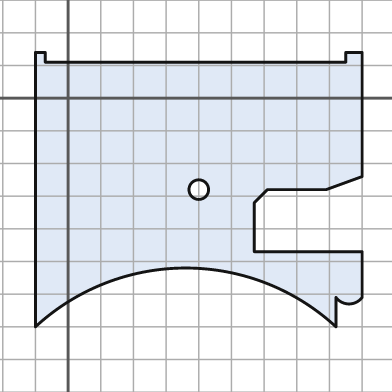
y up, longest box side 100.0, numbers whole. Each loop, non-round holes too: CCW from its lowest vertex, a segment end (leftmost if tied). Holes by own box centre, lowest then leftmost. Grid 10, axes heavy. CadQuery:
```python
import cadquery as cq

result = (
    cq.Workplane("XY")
    .moveTo(-10.0, -70.0)
    .threePointArc((36.0, -52.0), (82.0, -70.0))
    .lineTo(82.0, -61.0)
    .threePointArc((86.0, -63.0), (90.0, -61.0))
    .lineTo(90.0, -47.0)
    .lineTo(57.0, -47.0)
    .lineTo(57.0, -32.0)
    .lineTo(61.0, -28.0)
    .lineTo(79.0, -28.0)
    .lineTo(90.0, -24.0)
    .lineTo(90.0, 14.0)
    .lineTo(85.0, 14.0)
    .lineTo(85.0, 11.0)
    .lineTo(-7.0, 11.0)
    .lineTo(-7.0, 14.0)
    .lineTo(-10.0, 14.0)
    .close()
    .moveTo(40.0, -28.0)
    .circle(3.0)
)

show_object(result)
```